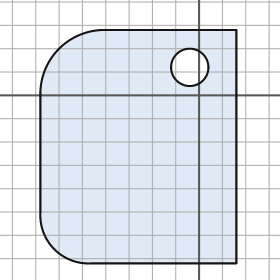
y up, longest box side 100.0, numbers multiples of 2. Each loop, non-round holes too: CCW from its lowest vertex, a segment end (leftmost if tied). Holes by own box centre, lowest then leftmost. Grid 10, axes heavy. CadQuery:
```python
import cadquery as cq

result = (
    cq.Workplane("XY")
    .moveTo(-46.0, -72.0)
    .lineTo(16.0, -72.0)
    .lineTo(16.0, 28.0)
    .lineTo(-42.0, 28.0)
    .threePointArc((-60.0, 20.0), (-68.0, 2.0))
    .lineTo(-68.0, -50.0)
    .threePointArc((-62.0, -66.0), (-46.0, -72.0))
    .close()
    .moveTo(-4.0, 12.0)
    .circle(8.0)
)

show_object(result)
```